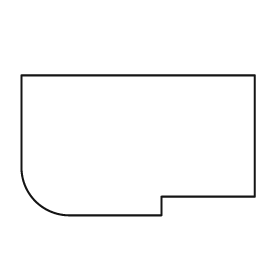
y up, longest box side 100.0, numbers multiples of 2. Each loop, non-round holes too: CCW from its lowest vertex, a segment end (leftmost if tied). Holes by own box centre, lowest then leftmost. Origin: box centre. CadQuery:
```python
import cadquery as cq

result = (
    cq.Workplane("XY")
    .moveTo(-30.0, -30.0)
    .lineTo(10.0, -30.0)
    .lineTo(10.0, -22.0)
    .lineTo(50.0, -22.0)
    .lineTo(50.0, 30.0)
    .lineTo(-50.0, 30.0)
    .lineTo(-50.0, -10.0)
    .threePointArc((-44.0, -24.0), (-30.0, -30.0))
    .close()
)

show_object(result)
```